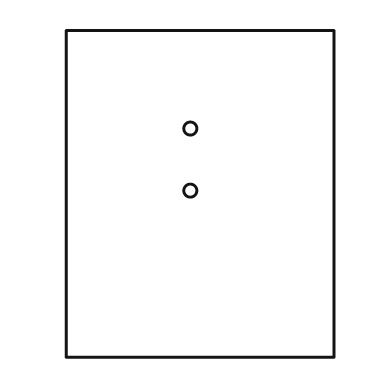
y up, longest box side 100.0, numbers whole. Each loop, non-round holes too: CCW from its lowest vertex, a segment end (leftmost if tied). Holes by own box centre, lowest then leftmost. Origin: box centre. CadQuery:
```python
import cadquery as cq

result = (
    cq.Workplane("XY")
    .moveTo(-41.0, -50.0)
    .lineTo(41.0, -50.0)
    .lineTo(41.0, 50.0)
    .lineTo(-41.0, 50.0)
    .close()
    .moveTo(-3.0, 1.0)
    .circle(2.0)
    .moveTo(-3.0, 20.0)
    .circle(2.0)
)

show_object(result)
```